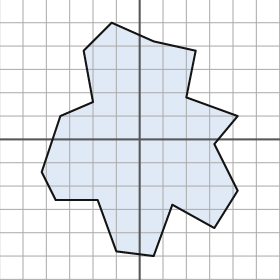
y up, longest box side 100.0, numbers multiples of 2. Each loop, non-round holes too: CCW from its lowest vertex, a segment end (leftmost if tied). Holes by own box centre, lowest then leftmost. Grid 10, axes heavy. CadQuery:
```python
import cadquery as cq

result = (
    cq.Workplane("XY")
    .moveTo(6.0, -50.0)
    .lineTo(14.0, -28.0)
    .lineTo(32.0, -38.0)
    .lineTo(42.0, -22.0)
    .lineTo(32.0, -2.0)
    .lineTo(42.0, 10.0)
    .lineTo(20.0, 18.0)
    .lineTo(24.0, 38.0)
    .lineTo(6.0, 42.0)
    .lineTo(-12.0, 50.0)
    .lineTo(-24.0, 38.0)
    .lineTo(-20.0, 16.0)
    .lineTo(-34.0, 10.0)
    .lineTo(-42.0, -14.0)
    .lineTo(-36.0, -26.0)
    .lineTo(-18.0, -26.0)
    .lineTo(-10.0, -48.0)
    .close()
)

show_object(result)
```